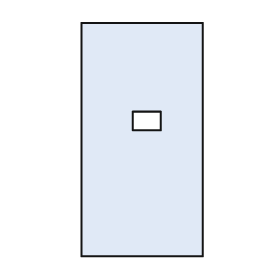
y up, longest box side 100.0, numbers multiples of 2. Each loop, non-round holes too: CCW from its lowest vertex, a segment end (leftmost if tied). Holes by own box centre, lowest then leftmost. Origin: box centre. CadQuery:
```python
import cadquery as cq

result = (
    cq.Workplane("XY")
    .moveTo(-26.0, -50.0)
    .lineTo(26.0, -50.0)
    .lineTo(26.0, 50.0)
    .lineTo(-26.0, 50.0)
    .close()
    .moveTo(-4.0, 4.0)
    .lineTo(8.0, 4.0)
    .lineTo(8.0, 12.0)
    .lineTo(-4.0, 12.0)
    .close()
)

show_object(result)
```